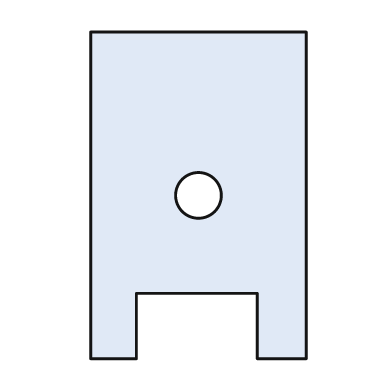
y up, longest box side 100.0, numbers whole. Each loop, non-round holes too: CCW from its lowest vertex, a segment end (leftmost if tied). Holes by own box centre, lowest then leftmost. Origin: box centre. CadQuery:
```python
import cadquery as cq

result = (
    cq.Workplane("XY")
    .moveTo(-33.0, -50.0)
    .lineTo(-19.0, -50.0)
    .lineTo(-19.0, -30.0)
    .lineTo(18.0, -30.0)
    .lineTo(18.0, -50.0)
    .lineTo(33.0, -50.0)
    .lineTo(33.0, 50.0)
    .lineTo(-33.0, 50.0)
    .close()
    .moveTo(0.0, 0.0)
    .circle(7.0)
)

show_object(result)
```